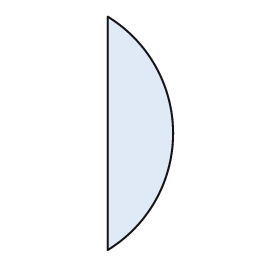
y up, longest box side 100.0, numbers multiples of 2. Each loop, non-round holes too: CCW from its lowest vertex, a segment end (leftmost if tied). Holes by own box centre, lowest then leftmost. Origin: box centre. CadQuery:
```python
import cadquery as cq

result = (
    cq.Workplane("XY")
    .moveTo(-14.0, -50.0)
    .threePointArc((14.0, 0.0), (-14.0, 50.0))
    .close()
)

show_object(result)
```